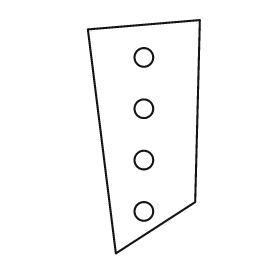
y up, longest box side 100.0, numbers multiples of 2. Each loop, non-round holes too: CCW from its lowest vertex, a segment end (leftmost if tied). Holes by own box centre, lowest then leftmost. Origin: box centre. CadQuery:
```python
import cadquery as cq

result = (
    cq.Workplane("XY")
    .moveTo(-12.0, -50.0)
    .lineTo(22.0, -28.0)
    .lineTo(24.0, 50.0)
    .lineTo(-24.0, 46.0)
    .close()
    .moveTo(0.0, -32.0)
    .circle(4.0)
    .moveTo(0.0, -10.0)
    .circle(4.0)
    .moveTo(0.0, 12.0)
    .circle(4.0)
    .moveTo(0.0, 34.0)
    .circle(4.0)
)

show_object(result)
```